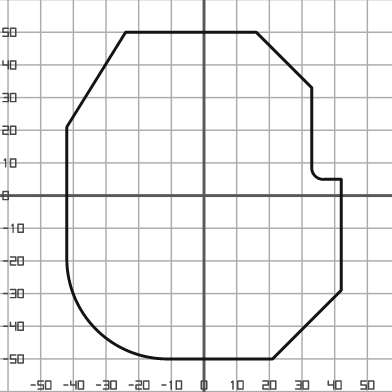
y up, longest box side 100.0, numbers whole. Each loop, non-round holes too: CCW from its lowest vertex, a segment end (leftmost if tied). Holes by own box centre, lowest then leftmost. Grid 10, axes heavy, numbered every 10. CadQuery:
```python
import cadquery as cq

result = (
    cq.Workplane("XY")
    .moveTo(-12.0, -50.0)
    .lineTo(21.0, -50.0)
    .lineTo(42.0, -29.0)
    .lineTo(42.0, 5.0)
    .lineTo(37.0, 5.0)
    .threePointArc((34.0, 6.0), (33.0, 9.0))
    .lineTo(33.0, 33.0)
    .lineTo(16.0, 50.0)
    .lineTo(-24.0, 50.0)
    .lineTo(-42.0, 21.0)
    .lineTo(-42.0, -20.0)
    .threePointArc((-33.0, -41.0), (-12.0, -50.0))
    .close()
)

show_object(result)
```